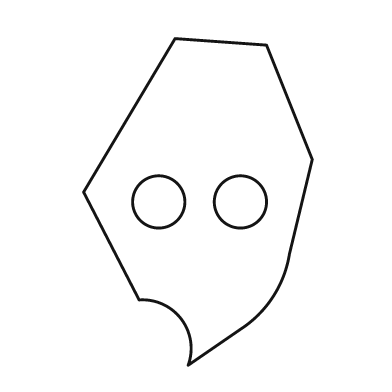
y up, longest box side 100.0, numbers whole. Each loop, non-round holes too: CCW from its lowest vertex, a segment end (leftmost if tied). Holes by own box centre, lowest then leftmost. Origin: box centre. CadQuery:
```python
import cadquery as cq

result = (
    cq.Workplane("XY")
    .moveTo(-3.0, -50.0)
    .lineTo(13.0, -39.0)
    .threePointArc((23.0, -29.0), (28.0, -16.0))
    .lineTo(35.0, 13.0)
    .lineTo(21.0, 48.0)
    .lineTo(-7.0, 50.0)
    .lineTo(-35.0, 3.0)
    .lineTo(-18.0, -30.0)
    .threePointArc((-5.0, -36.0), (-3.0, -50.0))
    .close()
    .moveTo(-12.0, 0.0)
    .circle(8.0)
    .moveTo(13.0, 0.0)
    .circle(8.0)
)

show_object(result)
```